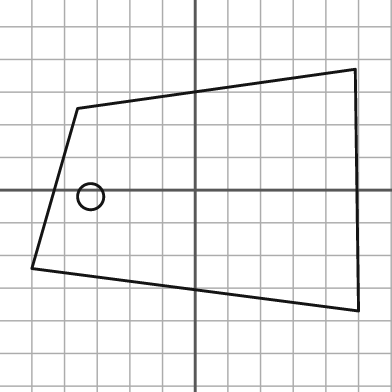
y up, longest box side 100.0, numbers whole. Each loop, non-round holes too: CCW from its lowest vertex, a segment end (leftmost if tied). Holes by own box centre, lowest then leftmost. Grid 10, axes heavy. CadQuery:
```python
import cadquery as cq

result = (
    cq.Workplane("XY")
    .moveTo(50.0, -37.0)
    .lineTo(49.0, 37.0)
    .lineTo(-36.0, 25.0)
    .lineTo(-50.0, -24.0)
    .close()
    .moveTo(-32.0, -2.0)
    .circle(4.0)
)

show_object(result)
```